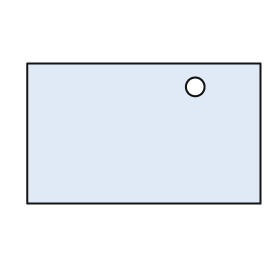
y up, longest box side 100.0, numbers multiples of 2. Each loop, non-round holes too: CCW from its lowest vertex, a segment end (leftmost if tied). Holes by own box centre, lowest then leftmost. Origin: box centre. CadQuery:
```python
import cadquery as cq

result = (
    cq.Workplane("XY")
    .moveTo(-50.0, -30.0)
    .lineTo(50.0, -30.0)
    .lineTo(50.0, 30.0)
    .lineTo(-50.0, 30.0)
    .close()
    .moveTo(22.0, 20.0)
    .circle(4.0)
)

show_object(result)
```